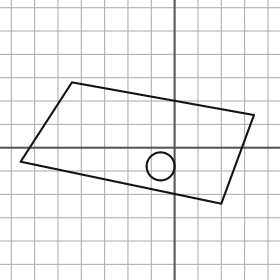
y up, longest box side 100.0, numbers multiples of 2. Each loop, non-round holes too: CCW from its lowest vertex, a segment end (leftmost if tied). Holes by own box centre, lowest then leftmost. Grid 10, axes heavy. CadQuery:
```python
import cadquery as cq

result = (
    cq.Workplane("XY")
    .moveTo(20.0, -24.0)
    .lineTo(34.0, 14.0)
    .lineTo(-44.0, 28.0)
    .lineTo(-66.0, -6.0)
    .close()
    .moveTo(-6.0, -8.0)
    .circle(6.0)
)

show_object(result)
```